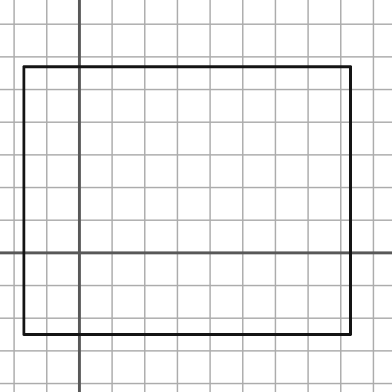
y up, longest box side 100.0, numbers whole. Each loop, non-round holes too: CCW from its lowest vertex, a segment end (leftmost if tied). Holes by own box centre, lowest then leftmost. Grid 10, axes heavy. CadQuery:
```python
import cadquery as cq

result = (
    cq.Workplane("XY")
    .moveTo(-17.0, -25.0)
    .lineTo(83.0, -25.0)
    .lineTo(83.0, 57.0)
    .lineTo(-17.0, 57.0)
    .close()
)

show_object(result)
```